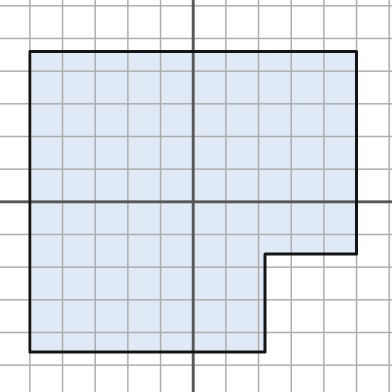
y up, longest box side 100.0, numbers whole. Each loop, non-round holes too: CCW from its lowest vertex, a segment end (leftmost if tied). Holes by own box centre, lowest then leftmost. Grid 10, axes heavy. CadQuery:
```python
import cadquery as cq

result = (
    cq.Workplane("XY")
    .moveTo(-50.0, -46.0)
    .lineTo(22.0, -46.0)
    .lineTo(22.0, -16.0)
    .lineTo(50.0, -16.0)
    .lineTo(50.0, 46.0)
    .lineTo(-50.0, 46.0)
    .close()
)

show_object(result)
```